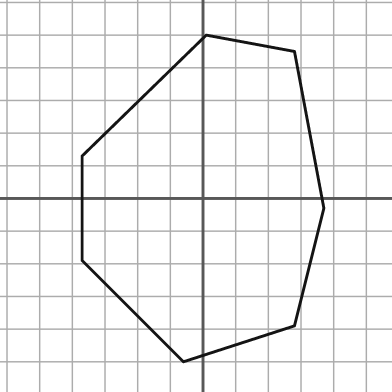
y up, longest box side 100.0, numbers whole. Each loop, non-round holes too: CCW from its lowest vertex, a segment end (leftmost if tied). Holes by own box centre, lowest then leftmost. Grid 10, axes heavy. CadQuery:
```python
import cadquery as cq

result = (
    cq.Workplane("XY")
    .moveTo(-6.0, -50.0)
    .lineTo(28.0, -39.0)
    .lineTo(37.0, -3.0)
    .lineTo(28.0, 45.0)
    .lineTo(1.0, 50.0)
    .lineTo(-37.0, 13.0)
    .lineTo(-37.0, -19.0)
    .close()
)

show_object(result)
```